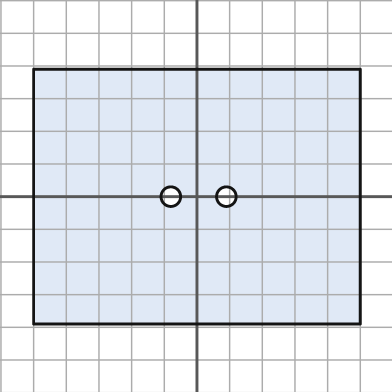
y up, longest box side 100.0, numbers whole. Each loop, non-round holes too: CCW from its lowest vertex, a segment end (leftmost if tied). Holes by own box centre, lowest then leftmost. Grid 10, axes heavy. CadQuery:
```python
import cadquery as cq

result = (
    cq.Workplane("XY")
    .moveTo(-50.0, -39.0)
    .lineTo(50.0, -39.0)
    .lineTo(50.0, 39.0)
    .lineTo(-50.0, 39.0)
    .close()
    .moveTo(-8.0, 0.0)
    .circle(3.0)
    .moveTo(9.0, 0.0)
    .circle(3.0)
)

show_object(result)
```